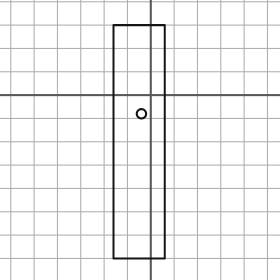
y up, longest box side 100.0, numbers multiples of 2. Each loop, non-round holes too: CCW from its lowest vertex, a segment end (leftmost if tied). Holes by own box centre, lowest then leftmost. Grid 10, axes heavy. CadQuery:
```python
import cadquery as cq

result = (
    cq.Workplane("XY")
    .moveTo(-16.0, -70.0)
    .lineTo(6.0, -70.0)
    .lineTo(6.0, 30.0)
    .lineTo(-16.0, 30.0)
    .close()
    .moveTo(-4.0, -8.0)
    .circle(2.0)
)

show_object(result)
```